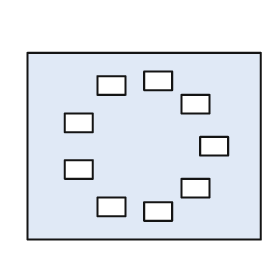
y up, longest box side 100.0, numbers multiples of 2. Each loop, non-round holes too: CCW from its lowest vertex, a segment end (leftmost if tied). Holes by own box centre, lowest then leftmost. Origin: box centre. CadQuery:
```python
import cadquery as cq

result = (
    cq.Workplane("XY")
    .moveTo(-50.0, -40.0)
    .lineTo(50.0, -40.0)
    .lineTo(50.0, 40.0)
    .lineTo(-50.0, 40.0)
    .close()
    .moveTo(0.0, -32.0)
    .lineTo(12.0, -32.0)
    .lineTo(12.0, -24.0)
    .lineTo(0.0, -24.0)
    .close()
    .moveTo(-20.0, -30.0)
    .lineTo(-8.0, -30.0)
    .lineTo(-8.0, -22.0)
    .lineTo(-20.0, -22.0)
    .close()
    .moveTo(16.0, -22.0)
    .lineTo(28.0, -22.0)
    .lineTo(28.0, -14.0)
    .lineTo(16.0, -14.0)
    .close()
    .moveTo(-34.0, -14.0)
    .lineTo(-22.0, -14.0)
    .lineTo(-22.0, -6.0)
    .lineTo(-34.0, -6.0)
    .close()
    .moveTo(24.0, -4.0)
    .lineTo(36.0, -4.0)
    .lineTo(36.0, 4.0)
    .lineTo(24.0, 4.0)
    .close()
    .moveTo(-34.0, 6.0)
    .lineTo(-22.0, 6.0)
    .lineTo(-22.0, 14.0)
    .lineTo(-34.0, 14.0)
    .close()
    .moveTo(16.0, 14.0)
    .lineTo(28.0, 14.0)
    .lineTo(28.0, 22.0)
    .lineTo(16.0, 22.0)
    .close()
    .moveTo(-20.0, 22.0)
    .lineTo(-8.0, 22.0)
    .lineTo(-8.0, 30.0)
    .lineTo(-20.0, 30.0)
    .close()
    .moveTo(0.0, 24.0)
    .lineTo(12.0, 24.0)
    .lineTo(12.0, 32.0)
    .lineTo(0.0, 32.0)
    .close()
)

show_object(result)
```